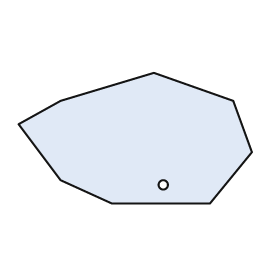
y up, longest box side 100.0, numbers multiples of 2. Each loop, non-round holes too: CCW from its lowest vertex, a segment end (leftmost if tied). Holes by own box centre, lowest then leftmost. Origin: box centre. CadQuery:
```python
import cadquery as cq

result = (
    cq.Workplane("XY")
    .moveTo(-10.0, -28.0)
    .lineTo(32.0, -28.0)
    .lineTo(50.0, -6.0)
    .lineTo(42.0, 16.0)
    .lineTo(8.0, 28.0)
    .lineTo(-32.0, 16.0)
    .lineTo(-50.0, 6.0)
    .lineTo(-32.0, -18.0)
    .close()
    .moveTo(12.0, -20.0)
    .circle(2.0)
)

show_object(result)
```